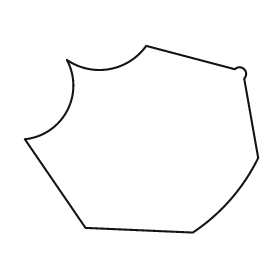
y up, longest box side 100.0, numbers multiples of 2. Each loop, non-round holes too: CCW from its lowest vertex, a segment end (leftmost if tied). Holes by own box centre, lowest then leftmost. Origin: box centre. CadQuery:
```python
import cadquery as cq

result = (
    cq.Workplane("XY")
    .moveTo(22.0, -40.0)
    .threePointArc((38.0, -26.0), (50.0, -8.0))
    .lineTo(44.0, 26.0)
    .threePointArc((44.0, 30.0), (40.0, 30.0))
    .lineTo(2.0, 40.0)
    .threePointArc((-14.0, 30.0), (-32.0, 34.0))
    .threePointArc((-32.0, 12.0), (-50.0, 0.0))
    .lineTo(-24.0, -38.0)
    .close()
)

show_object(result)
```